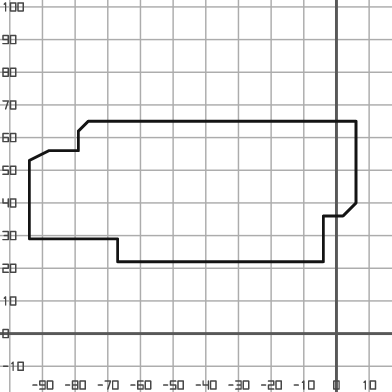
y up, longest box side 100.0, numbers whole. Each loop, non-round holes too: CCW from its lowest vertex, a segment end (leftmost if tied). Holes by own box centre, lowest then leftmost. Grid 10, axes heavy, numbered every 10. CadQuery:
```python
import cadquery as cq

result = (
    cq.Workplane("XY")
    .moveTo(-67.0, 22.0)
    .lineTo(-4.0, 22.0)
    .lineTo(-4.0, 36.0)
    .lineTo(2.0, 36.0)
    .lineTo(6.0, 40.0)
    .lineTo(6.0, 65.0)
    .lineTo(-76.0, 65.0)
    .lineTo(-79.0, 62.0)
    .lineTo(-79.0, 56.0)
    .lineTo(-88.0, 56.0)
    .lineTo(-94.0, 53.0)
    .lineTo(-94.0, 29.0)
    .lineTo(-67.0, 29.0)
    .close()
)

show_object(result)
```